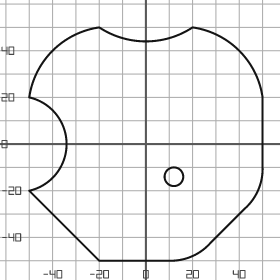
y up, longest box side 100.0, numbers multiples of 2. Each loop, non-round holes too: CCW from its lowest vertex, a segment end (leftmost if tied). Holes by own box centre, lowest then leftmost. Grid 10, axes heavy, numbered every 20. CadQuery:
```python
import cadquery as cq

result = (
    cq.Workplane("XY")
    .moveTo(-20.0, -50.0)
    .lineTo(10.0, -50.0)
    .threePointArc((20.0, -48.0), (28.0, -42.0))
    .lineTo(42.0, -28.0)
    .threePointArc((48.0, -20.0), (50.0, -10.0))
    .lineTo(50.0, 20.0)
    .threePointArc((40.0, 40.0), (20.0, 50.0))
    .threePointArc((0.0, 44.0), (-20.0, 50.0))
    .threePointArc((-40.0, 40.0), (-50.0, 20.0))
    .threePointArc((-34.0, 0.0), (-50.0, -20.0))
    .close()
    .moveTo(12.0, -14.0)
    .circle(4.0)
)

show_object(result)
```